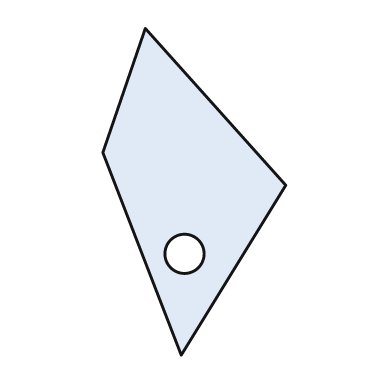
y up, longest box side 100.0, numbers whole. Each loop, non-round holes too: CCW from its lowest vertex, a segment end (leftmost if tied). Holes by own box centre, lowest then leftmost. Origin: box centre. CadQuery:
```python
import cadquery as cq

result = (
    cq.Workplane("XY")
    .moveTo(-4.0, -50.0)
    .lineTo(28.0, 2.0)
    .lineTo(-15.0, 50.0)
    .lineTo(-28.0, 12.0)
    .close()
    .moveTo(-3.0, -19.0)
    .circle(6.0)
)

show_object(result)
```